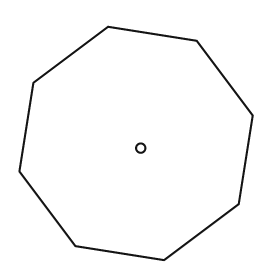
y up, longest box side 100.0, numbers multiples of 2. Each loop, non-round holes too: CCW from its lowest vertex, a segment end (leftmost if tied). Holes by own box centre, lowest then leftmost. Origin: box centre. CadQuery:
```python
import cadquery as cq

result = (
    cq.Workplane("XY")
    .moveTo(12.0, -50.0)
    .lineTo(44.0, -26.0)
    .lineTo(50.0, 12.0)
    .lineTo(26.0, 44.0)
    .lineTo(-12.0, 50.0)
    .lineTo(-44.0, 26.0)
    .lineTo(-50.0, -12.0)
    .lineTo(-26.0, -44.0)
    .close()
    .moveTo(2.0, -2.0)
    .circle(2.0)
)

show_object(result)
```